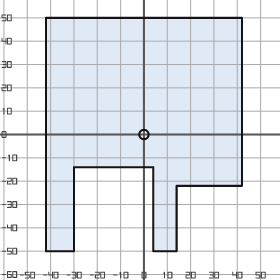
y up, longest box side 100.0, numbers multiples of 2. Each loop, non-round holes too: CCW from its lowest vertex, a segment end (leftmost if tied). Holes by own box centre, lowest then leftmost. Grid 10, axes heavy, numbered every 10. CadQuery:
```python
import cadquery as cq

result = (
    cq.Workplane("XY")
    .moveTo(-42.0, -50.0)
    .lineTo(-30.0, -50.0)
    .lineTo(-30.0, -14.0)
    .lineTo(4.0, -14.0)
    .lineTo(4.0, -50.0)
    .lineTo(14.0, -50.0)
    .lineTo(14.0, -22.0)
    .lineTo(42.0, -22.0)
    .lineTo(42.0, 50.0)
    .lineTo(-42.0, 50.0)
    .close()
    .moveTo(0.0, 0.0)
    .circle(2.0)
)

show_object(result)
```